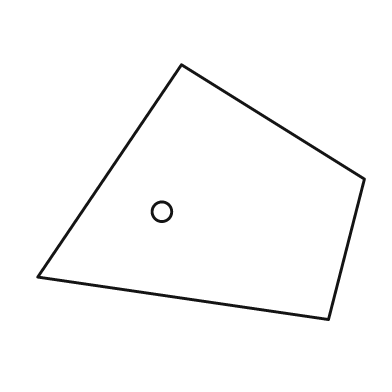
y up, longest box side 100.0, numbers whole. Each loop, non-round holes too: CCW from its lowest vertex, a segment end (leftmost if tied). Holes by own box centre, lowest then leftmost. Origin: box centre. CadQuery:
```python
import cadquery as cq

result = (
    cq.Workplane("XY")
    .moveTo(39.0, -39.0)
    .lineTo(50.0, 4.0)
    .lineTo(-6.0, 39.0)
    .lineTo(-50.0, -26.0)
    .close()
    .moveTo(-12.0, -6.0)
    .circle(3.0)
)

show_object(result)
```